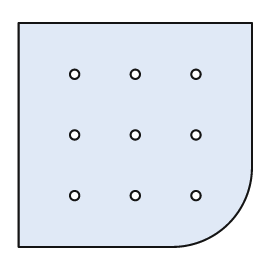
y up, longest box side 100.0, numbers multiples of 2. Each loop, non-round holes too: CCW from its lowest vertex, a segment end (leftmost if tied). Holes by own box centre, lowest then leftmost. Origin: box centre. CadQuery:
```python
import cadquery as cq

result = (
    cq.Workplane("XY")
    .moveTo(-50.0, -48.0)
    .lineTo(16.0, -48.0)
    .threePointArc((40.0, -38.0), (50.0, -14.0))
    .lineTo(50.0, 48.0)
    .lineTo(-50.0, 48.0)
    .close()
    .moveTo(-26.0, -26.0)
    .circle(2.0)
    .moveTo(0.0, -26.0)
    .circle(2.0)
    .moveTo(26.0, -26.0)
    .circle(2.0)
    .moveTo(-26.0, 0.0)
    .circle(2.0)
    .moveTo(0.0, 0.0)
    .circle(2.0)
    .moveTo(26.0, 0.0)
    .circle(2.0)
    .moveTo(-26.0, 26.0)
    .circle(2.0)
    .moveTo(0.0, 26.0)
    .circle(2.0)
    .moveTo(26.0, 26.0)
    .circle(2.0)
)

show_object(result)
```